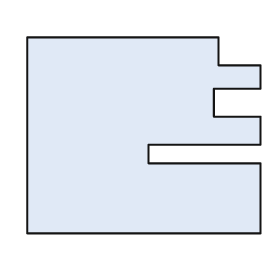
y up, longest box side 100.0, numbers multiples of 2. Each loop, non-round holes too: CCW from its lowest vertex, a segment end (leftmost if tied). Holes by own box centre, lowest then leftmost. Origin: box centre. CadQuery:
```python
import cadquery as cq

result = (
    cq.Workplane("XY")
    .moveTo(-50.0, -42.0)
    .lineTo(50.0, -42.0)
    .lineTo(50.0, -12.0)
    .lineTo(2.0, -12.0)
    .lineTo(2.0, -4.0)
    .lineTo(50.0, -4.0)
    .lineTo(50.0, 8.0)
    .lineTo(30.0, 8.0)
    .lineTo(30.0, 20.0)
    .lineTo(50.0, 20.0)
    .lineTo(50.0, 30.0)
    .lineTo(32.0, 30.0)
    .lineTo(32.0, 42.0)
    .lineTo(-50.0, 42.0)
    .close()
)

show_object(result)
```